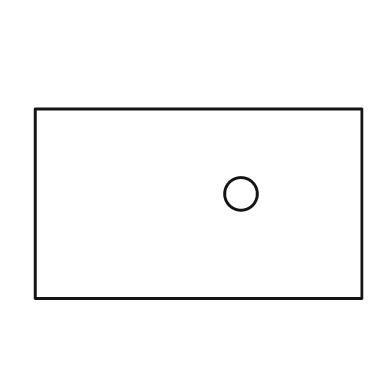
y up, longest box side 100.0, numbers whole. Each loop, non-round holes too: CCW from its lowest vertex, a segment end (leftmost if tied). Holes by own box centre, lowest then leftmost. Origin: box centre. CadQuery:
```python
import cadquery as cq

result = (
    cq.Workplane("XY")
    .moveTo(-50.0, -29.0)
    .lineTo(50.0, -29.0)
    .lineTo(50.0, 29.0)
    .lineTo(-50.0, 29.0)
    .close()
    .moveTo(13.0, 3.0)
    .circle(5.0)
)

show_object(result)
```